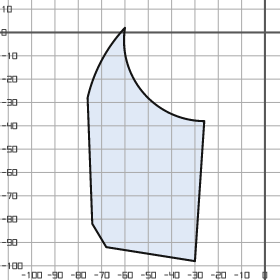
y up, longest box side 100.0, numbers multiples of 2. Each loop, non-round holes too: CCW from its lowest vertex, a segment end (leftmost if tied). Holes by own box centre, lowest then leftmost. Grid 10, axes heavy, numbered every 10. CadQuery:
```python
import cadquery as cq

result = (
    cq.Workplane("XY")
    .moveTo(-30.0, -98.0)
    .lineTo(-26.0, -38.0)
    .threePointArc((-52.0, -26.0), (-60.0, 2.0))
    .threePointArc((-70.0, -12.0), (-76.0, -28.0))
    .lineTo(-74.0, -82.0)
    .lineTo(-68.0, -92.0)
    .close()
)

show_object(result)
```